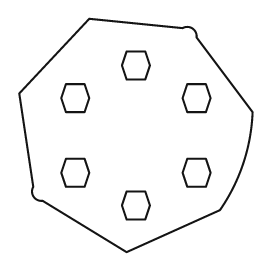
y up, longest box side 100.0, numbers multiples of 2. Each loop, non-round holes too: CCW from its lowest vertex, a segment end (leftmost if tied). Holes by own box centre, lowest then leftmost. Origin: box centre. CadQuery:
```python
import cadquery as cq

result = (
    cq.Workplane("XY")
    .moveTo(-4.0, -50.0)
    .lineTo(36.0, -32.0)
    .threePointArc((46.0, -12.0), (50.0, 10.0))
    .lineTo(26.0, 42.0)
    .threePointArc((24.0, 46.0), (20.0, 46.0))
    .lineTo(-20.0, 50.0)
    .lineTo(-50.0, 18.0)
    .lineTo(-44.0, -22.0)
    .threePointArc((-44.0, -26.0), (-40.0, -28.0))
    .close()
    .moveTo(-4.0, -36.0)
    .lineTo(4.0, -36.0)
    .lineTo(6.0, -30.0)
    .lineTo(4.0, -24.0)
    .lineTo(-4.0, -24.0)
    .lineTo(-6.0, -30.0)
    .close()
    .moveTo(-30.0, -22.0)
    .lineTo(-22.0, -22.0)
    .lineTo(-20.0, -16.0)
    .lineTo(-22.0, -10.0)
    .lineTo(-30.0, -10.0)
    .lineTo(-32.0, -16.0)
    .close()
    .moveTo(22.0, -22.0)
    .lineTo(30.0, -22.0)
    .lineTo(32.0, -16.0)
    .lineTo(30.0, -10.0)
    .lineTo(22.0, -10.0)
    .lineTo(20.0, -16.0)
    .close()
    .moveTo(-30.0, 10.0)
    .lineTo(-22.0, 10.0)
    .lineTo(-20.0, 16.0)
    .lineTo(-22.0, 22.0)
    .lineTo(-30.0, 22.0)
    .lineTo(-32.0, 16.0)
    .close()
    .moveTo(22.0, 10.0)
    .lineTo(30.0, 10.0)
    .lineTo(32.0, 16.0)
    .lineTo(30.0, 22.0)
    .lineTo(22.0, 22.0)
    .lineTo(20.0, 16.0)
    .close()
    .moveTo(-4.0, 24.0)
    .lineTo(4.0, 24.0)
    .lineTo(6.0, 30.0)
    .lineTo(4.0, 36.0)
    .lineTo(-4.0, 36.0)
    .lineTo(-6.0, 30.0)
    .close()
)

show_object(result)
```